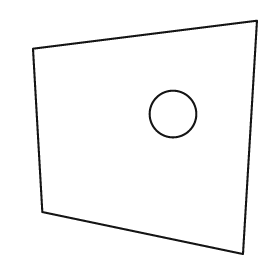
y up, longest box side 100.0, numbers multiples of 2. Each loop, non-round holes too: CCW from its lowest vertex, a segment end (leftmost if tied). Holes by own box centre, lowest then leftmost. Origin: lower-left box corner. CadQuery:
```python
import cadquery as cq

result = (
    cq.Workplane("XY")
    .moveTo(90.0, 0.0)
    .lineTo(96.0, 100.0)
    .lineTo(0.0, 88.0)
    .lineTo(4.0, 18.0)
    .close()
    .moveTo(60.0, 60.0)
    .circle(10.0)
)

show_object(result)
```